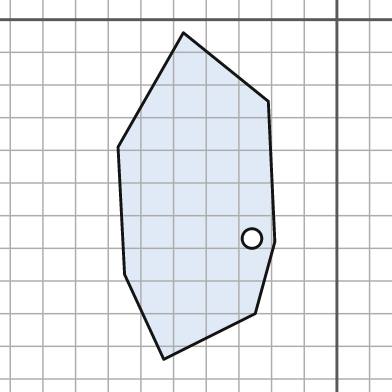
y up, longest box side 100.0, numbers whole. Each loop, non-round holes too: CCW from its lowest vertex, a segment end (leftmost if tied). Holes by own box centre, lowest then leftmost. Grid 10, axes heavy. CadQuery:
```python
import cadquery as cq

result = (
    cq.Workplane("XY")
    .moveTo(-53.0, -104.0)
    .lineTo(-25.0, -90.0)
    .lineTo(-19.0, -68.0)
    .lineTo(-21.0, -25.0)
    .lineTo(-47.0, -4.0)
    .lineTo(-67.0, -39.0)
    .lineTo(-65.0, -78.0)
    .close()
    .moveTo(-26.0, -67.0)
    .circle(3.0)
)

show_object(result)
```